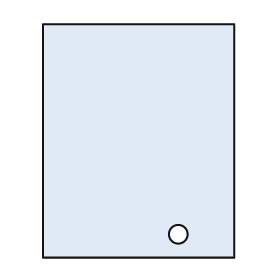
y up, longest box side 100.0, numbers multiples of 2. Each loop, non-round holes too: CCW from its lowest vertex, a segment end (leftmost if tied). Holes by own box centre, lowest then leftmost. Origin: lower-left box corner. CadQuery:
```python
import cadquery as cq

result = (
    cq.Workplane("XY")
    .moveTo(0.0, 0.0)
    .lineTo(82.0, 0.0)
    .lineTo(82.0, 100.0)
    .lineTo(0.0, 100.0)
    .close()
    .moveTo(58.0, 10.0)
    .circle(4.0)
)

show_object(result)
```